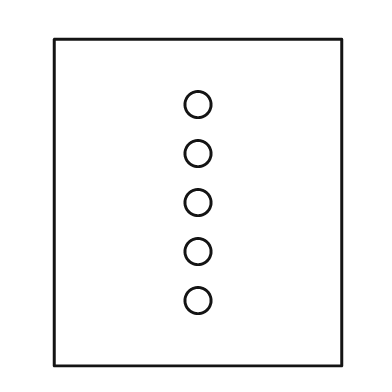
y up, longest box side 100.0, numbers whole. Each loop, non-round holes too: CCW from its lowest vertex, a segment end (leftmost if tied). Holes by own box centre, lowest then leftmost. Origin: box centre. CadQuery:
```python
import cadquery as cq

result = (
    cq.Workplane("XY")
    .moveTo(-44.0, -50.0)
    .lineTo(44.0, -50.0)
    .lineTo(44.0, 50.0)
    .lineTo(-44.0, 50.0)
    .close()
    .moveTo(0.0, -30.0)
    .circle(4.0)
    .moveTo(0.0, -15.0)
    .circle(4.0)
    .moveTo(0.0, 0.0)
    .circle(4.0)
    .moveTo(0.0, 15.0)
    .circle(4.0)
    .moveTo(0.0, 30.0)
    .circle(4.0)
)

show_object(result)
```